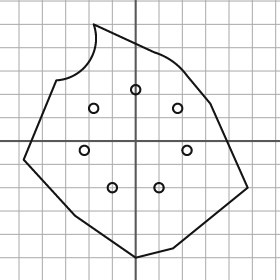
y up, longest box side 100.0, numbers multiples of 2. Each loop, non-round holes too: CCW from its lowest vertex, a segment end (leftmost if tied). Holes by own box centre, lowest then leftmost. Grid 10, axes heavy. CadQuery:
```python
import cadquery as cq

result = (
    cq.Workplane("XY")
    .moveTo(0.0, -50.0)
    .lineTo(16.0, -46.0)
    .lineTo(48.0, -20.0)
    .lineTo(32.0, 16.0)
    .lineTo(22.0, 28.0)
    .threePointArc((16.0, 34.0), (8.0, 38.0))
    .lineTo(-18.0, 50.0)
    .threePointArc((-20.0, 34.0), (-34.0, 26.0))
    .lineTo(-48.0, -8.0)
    .lineTo(-26.0, -32.0)
    .close()
    .moveTo(-10.0, -20.0)
    .circle(2.0)
    .moveTo(10.0, -20.0)
    .circle(2.0)
    .moveTo(-22.0, -4.0)
    .circle(2.0)
    .moveTo(22.0, -4.0)
    .circle(2.0)
    .moveTo(-18.0, 14.0)
    .circle(2.0)
    .moveTo(18.0, 14.0)
    .circle(2.0)
    .moveTo(0.0, 22.0)
    .circle(2.0)
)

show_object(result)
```